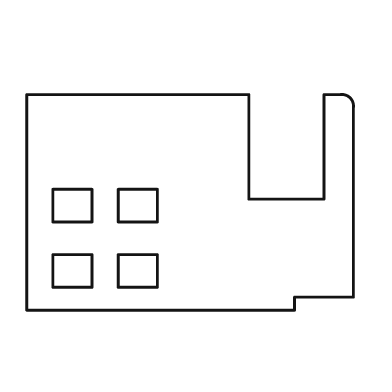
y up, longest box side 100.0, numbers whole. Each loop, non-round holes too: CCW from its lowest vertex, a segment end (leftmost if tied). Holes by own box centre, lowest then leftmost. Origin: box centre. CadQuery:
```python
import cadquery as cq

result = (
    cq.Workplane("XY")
    .moveTo(-50.0, -33.0)
    .lineTo(32.0, -33.0)
    .lineTo(32.0, -29.0)
    .lineTo(50.0, -29.0)
    .lineTo(50.0, 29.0)
    .threePointArc((49.0, 32.0), (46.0, 33.0))
    .lineTo(41.0, 33.0)
    .lineTo(41.0, 1.0)
    .lineTo(18.0, 1.0)
    .lineTo(18.0, 33.0)
    .lineTo(-50.0, 33.0)
    .close()
    .moveTo(-42.0, -26.0)
    .lineTo(-30.0, -26.0)
    .lineTo(-30.0, -16.0)
    .lineTo(-42.0, -16.0)
    .close()
    .moveTo(-22.0, -26.0)
    .lineTo(-10.0, -26.0)
    .lineTo(-10.0, -16.0)
    .lineTo(-22.0, -16.0)
    .close()
    .moveTo(-42.0, -6.0)
    .lineTo(-30.0, -6.0)
    .lineTo(-30.0, 4.0)
    .lineTo(-42.0, 4.0)
    .close()
    .moveTo(-22.0, -6.0)
    .lineTo(-10.0, -6.0)
    .lineTo(-10.0, 4.0)
    .lineTo(-22.0, 4.0)
    .close()
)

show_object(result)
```